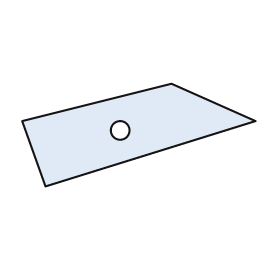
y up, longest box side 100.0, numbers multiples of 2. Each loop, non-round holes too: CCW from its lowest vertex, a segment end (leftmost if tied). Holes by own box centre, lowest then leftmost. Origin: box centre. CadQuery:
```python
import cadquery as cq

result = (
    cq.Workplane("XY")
    .moveTo(-40.0, -22.0)
    .lineTo(50.0, 6.0)
    .lineTo(14.0, 22.0)
    .lineTo(-50.0, 6.0)
    .close()
    .moveTo(-8.0, 2.0)
    .circle(4.0)
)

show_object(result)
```